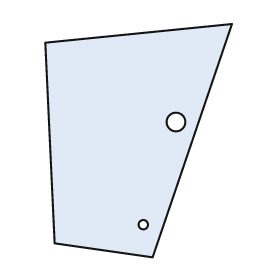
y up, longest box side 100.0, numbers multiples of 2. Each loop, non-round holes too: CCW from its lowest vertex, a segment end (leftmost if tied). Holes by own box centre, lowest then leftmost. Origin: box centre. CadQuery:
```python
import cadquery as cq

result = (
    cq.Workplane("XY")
    .moveTo(6.0, -50.0)
    .lineTo(40.0, 50.0)
    .lineTo(-40.0, 42.0)
    .lineTo(-36.0, -44.0)
    .close()
    .moveTo(2.0, -36.0)
    .circle(2.0)
    .moveTo(16.0, 8.0)
    .circle(4.0)
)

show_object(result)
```